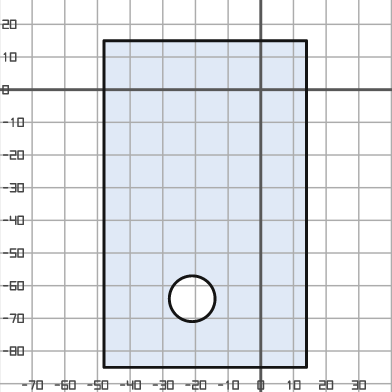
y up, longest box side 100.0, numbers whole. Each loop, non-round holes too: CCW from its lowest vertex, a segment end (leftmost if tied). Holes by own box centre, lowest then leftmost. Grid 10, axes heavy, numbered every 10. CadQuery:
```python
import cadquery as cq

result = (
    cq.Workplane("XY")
    .moveTo(-48.0, -85.0)
    .lineTo(14.0, -85.0)
    .lineTo(14.0, 15.0)
    .lineTo(-48.0, 15.0)
    .close()
    .moveTo(-21.0, -64.0)
    .circle(7.0)
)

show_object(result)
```